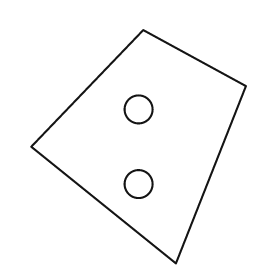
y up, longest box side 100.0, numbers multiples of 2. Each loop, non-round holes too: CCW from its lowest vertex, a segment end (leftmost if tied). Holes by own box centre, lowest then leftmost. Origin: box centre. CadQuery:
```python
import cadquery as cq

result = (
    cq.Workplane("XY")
    .moveTo(16.0, -50.0)
    .lineTo(46.0, 26.0)
    .lineTo(2.0, 50.0)
    .lineTo(-46.0, 0.0)
    .close()
    .moveTo(0.0, -16.0)
    .circle(6.0)
    .moveTo(0.0, 16.0)
    .circle(6.0)
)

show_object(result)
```